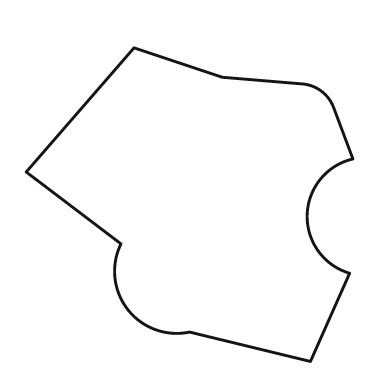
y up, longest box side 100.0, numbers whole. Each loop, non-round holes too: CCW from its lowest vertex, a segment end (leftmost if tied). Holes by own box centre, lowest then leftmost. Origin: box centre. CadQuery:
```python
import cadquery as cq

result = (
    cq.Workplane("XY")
    .moveTo(37.0, -48.0)
    .lineTo(49.0, -21.0)
    .threePointArc((36.0, -3.0), (50.0, 14.0))
    .lineTo(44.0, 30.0)
    .threePointArc((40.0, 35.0), (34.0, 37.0))
    .lineTo(10.0, 39.0)
    .lineTo(-17.0, 48.0)
    .lineTo(-50.0, 10.0)
    .lineTo(-21.0, -12.0)
    .threePointArc((-19.0, -32.0), (0.0, -39.0))
    .close()
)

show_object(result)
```